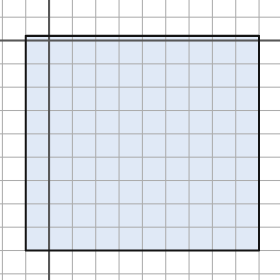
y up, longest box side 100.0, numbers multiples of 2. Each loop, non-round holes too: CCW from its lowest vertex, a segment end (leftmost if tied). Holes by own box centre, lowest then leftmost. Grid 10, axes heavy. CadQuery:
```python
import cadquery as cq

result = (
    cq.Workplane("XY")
    .moveTo(-10.0, -90.0)
    .lineTo(90.0, -90.0)
    .lineTo(90.0, 2.0)
    .lineTo(-10.0, 2.0)
    .close()
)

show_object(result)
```